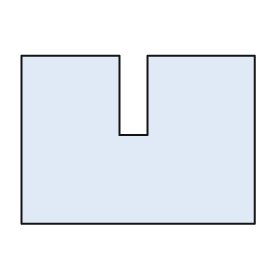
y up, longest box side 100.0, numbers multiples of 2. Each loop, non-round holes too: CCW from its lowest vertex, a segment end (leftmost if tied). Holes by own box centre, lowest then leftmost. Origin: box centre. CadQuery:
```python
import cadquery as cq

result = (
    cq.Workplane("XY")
    .moveTo(-50.0, -36.0)
    .lineTo(50.0, -36.0)
    .lineTo(50.0, 36.0)
    .lineTo(4.0, 36.0)
    .lineTo(4.0, 2.0)
    .lineTo(-8.0, 2.0)
    .lineTo(-8.0, 36.0)
    .lineTo(-50.0, 36.0)
    .close()
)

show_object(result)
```